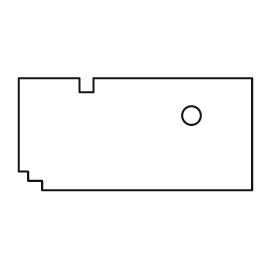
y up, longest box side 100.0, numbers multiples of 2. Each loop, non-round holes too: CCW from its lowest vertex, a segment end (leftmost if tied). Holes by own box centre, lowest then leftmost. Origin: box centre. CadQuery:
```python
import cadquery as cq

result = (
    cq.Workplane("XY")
    .moveTo(-40.0, -24.0)
    .lineTo(50.0, -24.0)
    .lineTo(50.0, 24.0)
    .lineTo(-18.0, 24.0)
    .lineTo(-18.0, 18.0)
    .lineTo(-24.0, 18.0)
    .lineTo(-24.0, 24.0)
    .lineTo(-50.0, 24.0)
    .lineTo(-50.0, -16.0)
    .lineTo(-46.0, -16.0)
    .lineTo(-46.0, -20.0)
    .lineTo(-40.0, -20.0)
    .close()
    .moveTo(24.0, 8.0)
    .circle(4.0)
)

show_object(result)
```